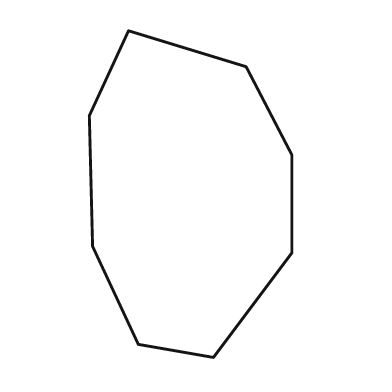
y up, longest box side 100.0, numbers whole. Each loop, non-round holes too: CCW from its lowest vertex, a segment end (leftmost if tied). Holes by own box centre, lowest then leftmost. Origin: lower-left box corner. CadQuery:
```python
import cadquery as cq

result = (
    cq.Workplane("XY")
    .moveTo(38.0, 0.0)
    .lineTo(62.0, 32.0)
    .lineTo(62.0, 62.0)
    .lineTo(48.0, 89.0)
    .lineTo(12.0, 100.0)
    .lineTo(0.0, 74.0)
    .lineTo(1.0, 34.0)
    .lineTo(15.0, 4.0)
    .close()
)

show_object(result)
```